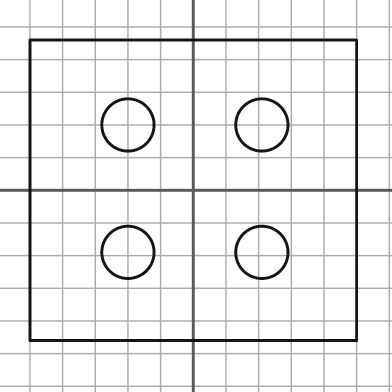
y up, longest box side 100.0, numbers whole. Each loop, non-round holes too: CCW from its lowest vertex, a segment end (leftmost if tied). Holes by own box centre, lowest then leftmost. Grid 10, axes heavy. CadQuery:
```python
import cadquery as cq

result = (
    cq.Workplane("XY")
    .moveTo(-50.0, -46.0)
    .lineTo(50.0, -46.0)
    .lineTo(50.0, 46.0)
    .lineTo(-50.0, 46.0)
    .close()
    .moveTo(-20.0, -19.0)
    .circle(8.0)
    .moveTo(21.0, -19.0)
    .circle(8.0)
    .moveTo(-20.0, 20.0)
    .circle(8.0)
    .moveTo(21.0, 20.0)
    .circle(8.0)
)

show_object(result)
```